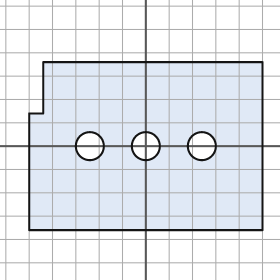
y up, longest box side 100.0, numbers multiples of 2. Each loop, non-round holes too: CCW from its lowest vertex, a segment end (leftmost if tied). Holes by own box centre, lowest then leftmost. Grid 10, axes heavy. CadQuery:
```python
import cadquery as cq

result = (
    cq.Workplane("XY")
    .moveTo(-50.0, -36.0)
    .lineTo(50.0, -36.0)
    .lineTo(50.0, 36.0)
    .lineTo(-44.0, 36.0)
    .lineTo(-44.0, 14.0)
    .lineTo(-50.0, 14.0)
    .close()
    .moveTo(-24.0, 0.0)
    .circle(6.0)
    .moveTo(0.0, 0.0)
    .circle(6.0)
    .moveTo(24.0, 0.0)
    .circle(6.0)
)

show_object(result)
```